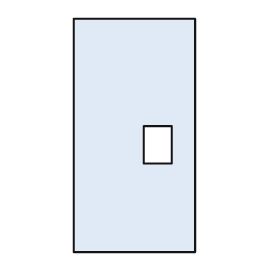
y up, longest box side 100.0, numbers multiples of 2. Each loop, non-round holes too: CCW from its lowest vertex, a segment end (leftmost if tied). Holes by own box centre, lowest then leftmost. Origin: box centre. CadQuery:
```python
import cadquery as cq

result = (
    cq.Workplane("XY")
    .moveTo(-26.0, -50.0)
    .lineTo(26.0, -50.0)
    .lineTo(26.0, 50.0)
    .lineTo(-26.0, 50.0)
    .close()
    .moveTo(4.0, -12.0)
    .lineTo(16.0, -12.0)
    .lineTo(16.0, 4.0)
    .lineTo(4.0, 4.0)
    .close()
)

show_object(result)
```